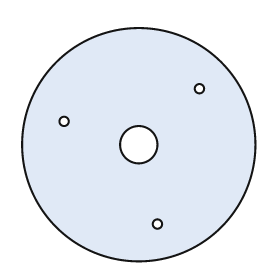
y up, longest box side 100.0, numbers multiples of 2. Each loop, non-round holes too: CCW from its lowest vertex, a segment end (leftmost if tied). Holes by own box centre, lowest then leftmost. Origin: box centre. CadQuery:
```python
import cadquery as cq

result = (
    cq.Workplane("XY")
    .moveTo(0.0, 0.0)
    .circle(50.0)
    .moveTo(8.0, -34.0)
    .circle(2.0)
    .moveTo(0.0, 0.0)
    .circle(8.0)
    .moveTo(-32.0, 10.0)
    .circle(2.0)
    .moveTo(26.0, 24.0)
    .circle(2.0)
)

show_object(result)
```